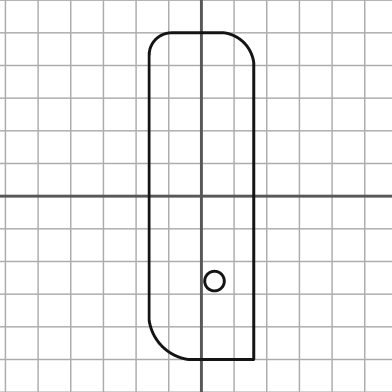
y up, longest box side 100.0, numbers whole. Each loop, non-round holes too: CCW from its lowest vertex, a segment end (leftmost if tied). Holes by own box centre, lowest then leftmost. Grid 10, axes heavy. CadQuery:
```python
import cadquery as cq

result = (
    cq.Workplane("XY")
    .moveTo(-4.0, -50.0)
    .lineTo(16.0, -50.0)
    .lineTo(16.0, 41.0)
    .threePointArc((13.0, 47.0), (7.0, 50.0))
    .lineTo(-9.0, 50.0)
    .threePointArc((-14.0, 48.0), (-16.0, 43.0))
    .lineTo(-16.0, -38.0)
    .threePointArc((-12.0, -46.0), (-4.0, -50.0))
    .close()
    .moveTo(4.0, -26.0)
    .circle(3.0)
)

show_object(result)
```